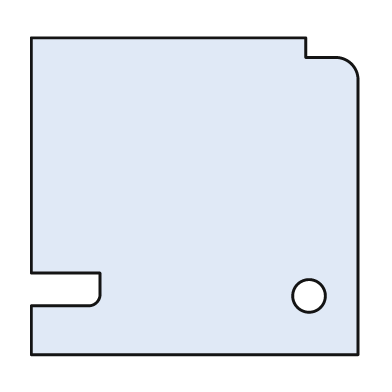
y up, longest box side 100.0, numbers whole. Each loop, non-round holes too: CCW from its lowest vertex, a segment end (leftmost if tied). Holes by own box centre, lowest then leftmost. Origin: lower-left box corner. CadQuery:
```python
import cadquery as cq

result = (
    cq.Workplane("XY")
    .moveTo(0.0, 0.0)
    .lineTo(100.0, 0.0)
    .lineTo(100.0, 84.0)
    .threePointArc((98.0, 89.0), (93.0, 91.0))
    .lineTo(84.0, 91.0)
    .lineTo(84.0, 97.0)
    .lineTo(0.0, 97.0)
    .lineTo(0.0, 25.0)
    .lineTo(21.0, 25.0)
    .lineTo(21.0, 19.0)
    .threePointArc((20.0, 16.0), (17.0, 15.0))
    .lineTo(0.0, 15.0)
    .close()
    .moveTo(85.0, 18.0)
    .circle(5.0)
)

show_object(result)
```